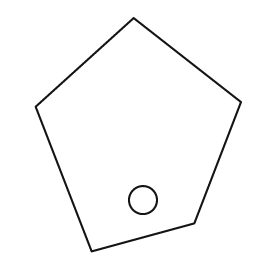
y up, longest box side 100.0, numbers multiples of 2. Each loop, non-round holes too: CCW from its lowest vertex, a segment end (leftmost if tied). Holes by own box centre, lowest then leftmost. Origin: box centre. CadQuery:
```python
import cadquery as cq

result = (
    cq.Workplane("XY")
    .moveTo(-20.0, -50.0)
    .lineTo(24.0, -38.0)
    .lineTo(44.0, 14.0)
    .lineTo(-2.0, 50.0)
    .lineTo(-44.0, 12.0)
    .close()
    .moveTo(2.0, -28.0)
    .circle(6.0)
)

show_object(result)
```